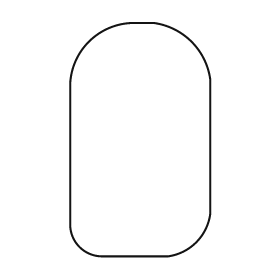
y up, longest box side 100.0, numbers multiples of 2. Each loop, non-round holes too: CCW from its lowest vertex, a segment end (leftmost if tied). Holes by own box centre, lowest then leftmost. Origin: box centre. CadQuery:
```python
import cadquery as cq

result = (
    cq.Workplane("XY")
    .moveTo(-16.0, -50.0)
    .lineTo(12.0, -50.0)
    .threePointArc((24.0, -44.0), (30.0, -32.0))
    .lineTo(30.0, 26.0)
    .threePointArc((22.0, 42.0), (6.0, 50.0))
    .lineTo(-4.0, 50.0)
    .threePointArc((-22.0, 42.0), (-30.0, 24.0))
    .lineTo(-30.0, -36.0)
    .threePointArc((-26.0, -46.0), (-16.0, -50.0))
    .close()
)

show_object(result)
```